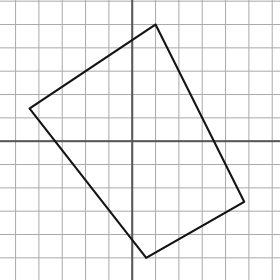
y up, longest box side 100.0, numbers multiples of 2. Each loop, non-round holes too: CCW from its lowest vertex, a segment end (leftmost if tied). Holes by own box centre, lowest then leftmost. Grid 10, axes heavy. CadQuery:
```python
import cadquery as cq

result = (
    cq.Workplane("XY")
    .moveTo(6.0, -50.0)
    .lineTo(48.0, -26.0)
    .lineTo(10.0, 50.0)
    .lineTo(-44.0, 14.0)
    .close()
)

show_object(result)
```